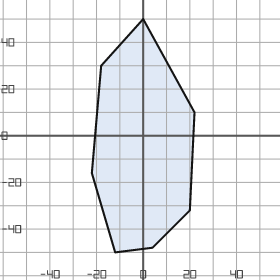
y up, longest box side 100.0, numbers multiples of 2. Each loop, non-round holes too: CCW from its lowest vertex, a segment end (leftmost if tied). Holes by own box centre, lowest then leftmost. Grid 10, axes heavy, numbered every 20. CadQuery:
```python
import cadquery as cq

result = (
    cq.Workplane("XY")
    .moveTo(-12.0, -50.0)
    .lineTo(4.0, -48.0)
    .lineTo(20.0, -32.0)
    .lineTo(22.0, 10.0)
    .lineTo(0.0, 50.0)
    .lineTo(-18.0, 30.0)
    .lineTo(-22.0, -16.0)
    .close()
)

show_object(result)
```